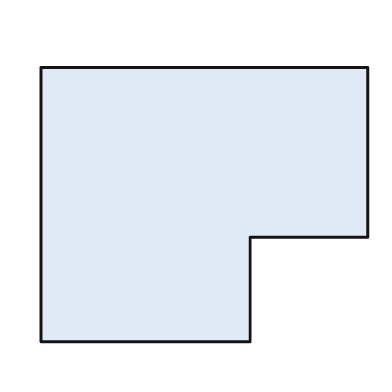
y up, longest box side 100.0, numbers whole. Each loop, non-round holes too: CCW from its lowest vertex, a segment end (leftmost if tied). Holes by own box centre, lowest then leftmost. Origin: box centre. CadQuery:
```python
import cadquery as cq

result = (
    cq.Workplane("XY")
    .moveTo(-50.0, -42.0)
    .lineTo(14.0, -42.0)
    .lineTo(14.0, -10.0)
    .lineTo(50.0, -10.0)
    .lineTo(50.0, 42.0)
    .lineTo(-50.0, 42.0)
    .close()
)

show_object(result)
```